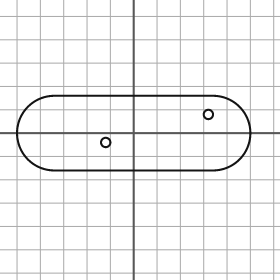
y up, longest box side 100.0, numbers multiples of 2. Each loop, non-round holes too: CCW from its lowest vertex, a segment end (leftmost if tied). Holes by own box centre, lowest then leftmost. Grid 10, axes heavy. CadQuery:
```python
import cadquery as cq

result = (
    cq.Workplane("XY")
    .moveTo(-34.0, -16.0)
    .lineTo(34.0, -16.0)
    .threePointArc((50.0, 0.0), (34.0, 16.0))
    .lineTo(-34.0, 16.0)
    .threePointArc((-50.0, 0.0), (-34.0, -16.0))
    .close()
    .moveTo(-12.0, -4.0)
    .circle(2.0)
    .moveTo(32.0, 8.0)
    .circle(2.0)
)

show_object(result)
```